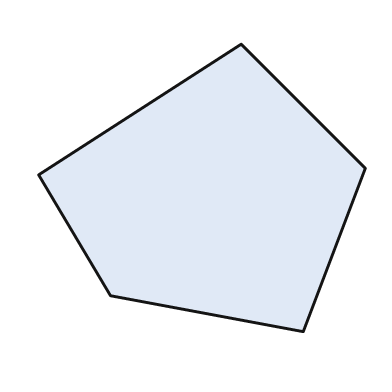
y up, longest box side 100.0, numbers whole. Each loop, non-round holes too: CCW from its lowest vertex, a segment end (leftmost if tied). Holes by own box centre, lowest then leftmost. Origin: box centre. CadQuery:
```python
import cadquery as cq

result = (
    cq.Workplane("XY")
    .moveTo(31.0, -44.0)
    .lineTo(50.0, 6.0)
    .lineTo(12.0, 44.0)
    .lineTo(-50.0, 4.0)
    .lineTo(-28.0, -33.0)
    .close()
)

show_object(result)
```